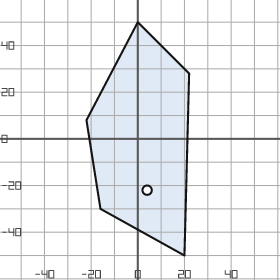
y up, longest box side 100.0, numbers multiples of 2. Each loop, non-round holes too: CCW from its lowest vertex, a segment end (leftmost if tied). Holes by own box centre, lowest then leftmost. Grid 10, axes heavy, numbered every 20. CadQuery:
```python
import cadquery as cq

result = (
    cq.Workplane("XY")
    .moveTo(20.0, -50.0)
    .lineTo(22.0, 28.0)
    .lineTo(0.0, 50.0)
    .lineTo(-22.0, 8.0)
    .lineTo(-16.0, -30.0)
    .close()
    .moveTo(4.0, -22.0)
    .circle(2.0)
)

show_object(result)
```